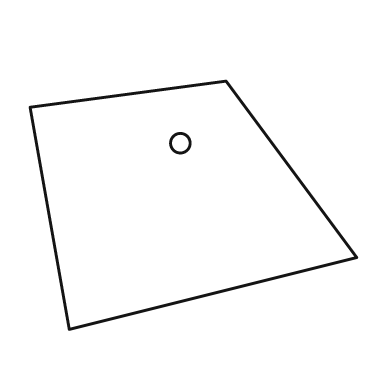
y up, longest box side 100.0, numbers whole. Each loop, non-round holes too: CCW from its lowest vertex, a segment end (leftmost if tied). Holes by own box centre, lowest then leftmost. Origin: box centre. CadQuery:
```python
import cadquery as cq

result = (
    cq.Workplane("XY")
    .moveTo(-38.0, -38.0)
    .lineTo(50.0, -16.0)
    .lineTo(10.0, 38.0)
    .lineTo(-50.0, 30.0)
    .close()
    .moveTo(-4.0, 19.0)
    .circle(3.0)
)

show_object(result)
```